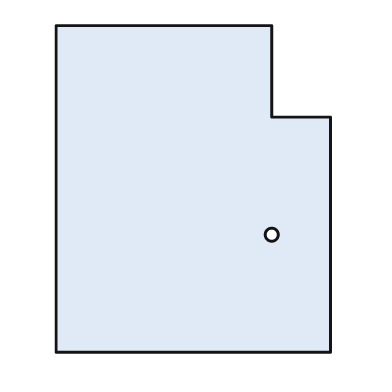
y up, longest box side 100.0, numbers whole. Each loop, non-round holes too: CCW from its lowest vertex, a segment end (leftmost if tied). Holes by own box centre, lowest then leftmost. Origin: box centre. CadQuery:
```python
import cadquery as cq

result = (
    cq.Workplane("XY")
    .moveTo(-42.0, -50.0)
    .lineTo(42.0, -50.0)
    .lineTo(42.0, 22.0)
    .lineTo(24.0, 22.0)
    .lineTo(24.0, 50.0)
    .lineTo(-42.0, 50.0)
    .close()
    .moveTo(24.0, -14.0)
    .circle(2.0)
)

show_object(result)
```